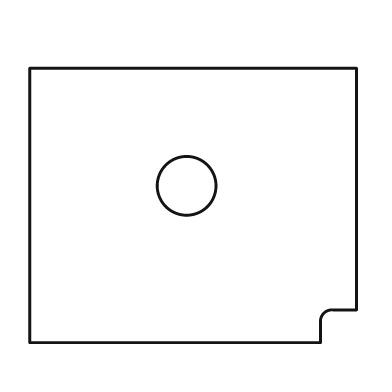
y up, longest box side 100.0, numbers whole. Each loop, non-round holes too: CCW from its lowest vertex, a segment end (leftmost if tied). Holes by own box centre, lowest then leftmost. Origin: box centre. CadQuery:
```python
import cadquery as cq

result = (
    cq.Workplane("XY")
    .moveTo(-50.0, -42.0)
    .lineTo(39.0, -42.0)
    .lineTo(39.0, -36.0)
    .threePointArc((40.0, -33.0), (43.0, -32.0))
    .lineTo(50.0, -32.0)
    .lineTo(50.0, 42.0)
    .lineTo(-50.0, 42.0)
    .close()
    .moveTo(-2.0, 6.0)
    .circle(9.0)
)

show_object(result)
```